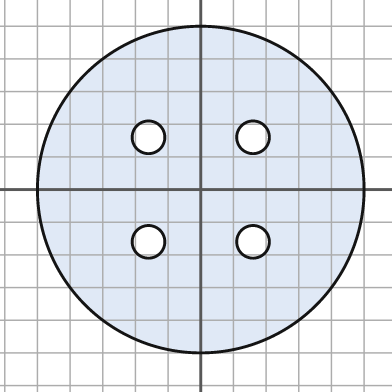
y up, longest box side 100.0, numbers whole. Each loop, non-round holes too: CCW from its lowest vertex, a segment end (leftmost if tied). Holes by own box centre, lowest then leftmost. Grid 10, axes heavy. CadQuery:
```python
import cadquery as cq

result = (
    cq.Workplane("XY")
    .moveTo(0.0, 0.0)
    .circle(50.0)
    .moveTo(-16.0, -16.0)
    .circle(5.0)
    .moveTo(16.0, -16.0)
    .circle(5.0)
    .moveTo(-16.0, 16.0)
    .circle(5.0)
    .moveTo(16.0, 16.0)
    .circle(5.0)
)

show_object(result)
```